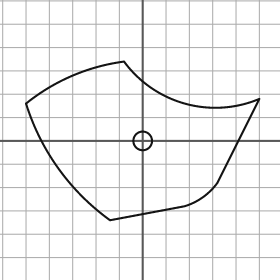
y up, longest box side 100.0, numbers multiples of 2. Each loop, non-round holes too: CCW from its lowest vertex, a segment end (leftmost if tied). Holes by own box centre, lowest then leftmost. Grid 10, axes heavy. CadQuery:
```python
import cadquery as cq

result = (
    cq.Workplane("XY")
    .moveTo(-14.0, -34.0)
    .lineTo(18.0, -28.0)
    .threePointArc((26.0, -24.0), (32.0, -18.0))
    .lineTo(50.0, 18.0)
    .threePointArc((18.0, 16.0), (-8.0, 34.0))
    .threePointArc((-30.0, 28.0), (-50.0, 16.0))
    .threePointArc((-36.0, -12.0), (-14.0, -34.0))
    .close()
    .moveTo(0.0, 0.0)
    .circle(4.0)
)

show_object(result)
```